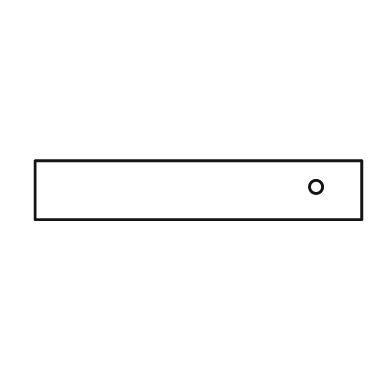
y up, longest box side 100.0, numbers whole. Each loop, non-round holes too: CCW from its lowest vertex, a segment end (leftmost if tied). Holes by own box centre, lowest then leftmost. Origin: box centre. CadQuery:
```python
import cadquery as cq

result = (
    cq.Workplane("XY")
    .moveTo(-50.0, -9.0)
    .lineTo(50.0, -9.0)
    .lineTo(50.0, 9.0)
    .lineTo(-50.0, 9.0)
    .close()
    .moveTo(36.0, 1.0)
    .circle(2.0)
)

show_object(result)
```